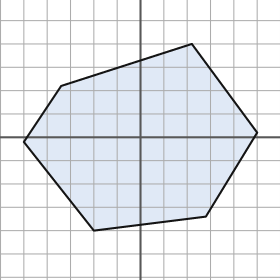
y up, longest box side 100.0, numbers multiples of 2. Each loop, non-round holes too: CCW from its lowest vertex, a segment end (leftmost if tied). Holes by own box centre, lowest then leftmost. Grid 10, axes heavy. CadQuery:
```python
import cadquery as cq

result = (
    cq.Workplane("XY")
    .moveTo(-20.0, -40.0)
    .lineTo(28.0, -34.0)
    .lineTo(50.0, 2.0)
    .lineTo(22.0, 40.0)
    .lineTo(-34.0, 22.0)
    .lineTo(-50.0, -2.0)
    .close()
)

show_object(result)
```